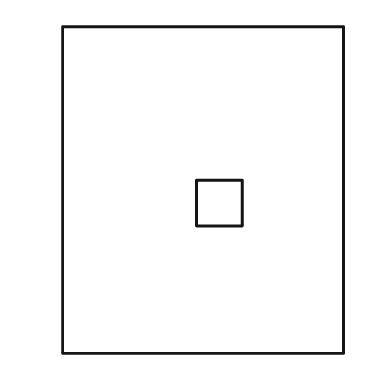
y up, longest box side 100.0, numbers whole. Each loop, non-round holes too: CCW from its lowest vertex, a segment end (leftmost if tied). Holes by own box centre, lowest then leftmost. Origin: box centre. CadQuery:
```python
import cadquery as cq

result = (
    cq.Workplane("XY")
    .moveTo(-43.0, -50.0)
    .lineTo(43.0, -50.0)
    .lineTo(43.0, 50.0)
    .lineTo(-43.0, 50.0)
    .close()
    .moveTo(-2.0, -11.0)
    .lineTo(12.0, -11.0)
    .lineTo(12.0, 3.0)
    .lineTo(-2.0, 3.0)
    .close()
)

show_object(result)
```